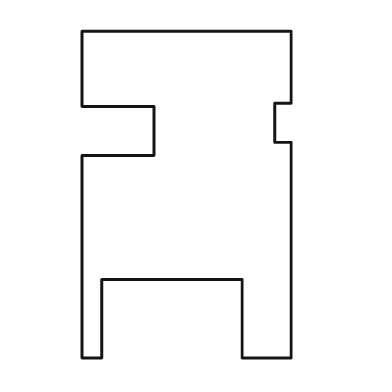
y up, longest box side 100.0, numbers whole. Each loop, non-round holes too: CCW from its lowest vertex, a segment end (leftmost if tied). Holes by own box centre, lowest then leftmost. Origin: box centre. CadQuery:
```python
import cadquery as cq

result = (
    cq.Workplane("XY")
    .moveTo(-32.0, -50.0)
    .lineTo(-26.0, -50.0)
    .lineTo(-26.0, -26.0)
    .lineTo(17.0, -26.0)
    .lineTo(17.0, -50.0)
    .lineTo(32.0, -50.0)
    .lineTo(32.0, 16.0)
    .lineTo(27.0, 16.0)
    .lineTo(27.0, 28.0)
    .lineTo(32.0, 28.0)
    .lineTo(32.0, 50.0)
    .lineTo(-32.0, 50.0)
    .lineTo(-32.0, 27.0)
    .lineTo(-10.0, 27.0)
    .lineTo(-10.0, 12.0)
    .lineTo(-32.0, 12.0)
    .close()
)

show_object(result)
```